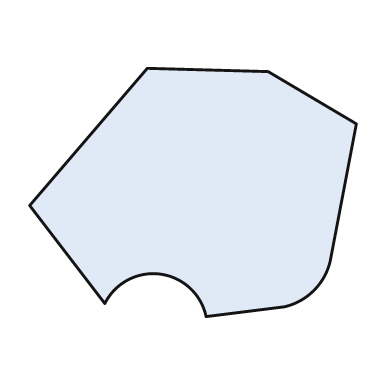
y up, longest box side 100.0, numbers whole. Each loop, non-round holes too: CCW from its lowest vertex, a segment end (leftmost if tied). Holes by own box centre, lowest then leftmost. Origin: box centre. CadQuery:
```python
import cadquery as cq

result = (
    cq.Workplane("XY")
    .moveTo(4.0, -38.0)
    .lineTo(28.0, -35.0)
    .threePointArc((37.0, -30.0), (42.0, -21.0))
    .lineTo(50.0, 21.0)
    .lineTo(23.0, 37.0)
    .lineTo(-14.0, 38.0)
    .lineTo(-50.0, -4.0)
    .lineTo(-27.0, -34.0)
    .threePointArc((-10.0, -25.0), (4.0, -38.0))
    .close()
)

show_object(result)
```